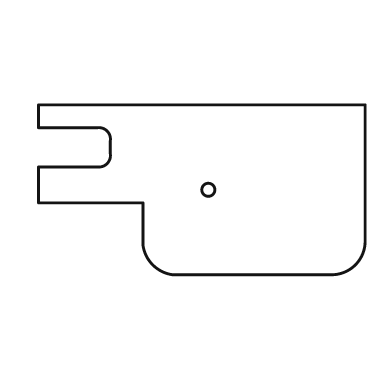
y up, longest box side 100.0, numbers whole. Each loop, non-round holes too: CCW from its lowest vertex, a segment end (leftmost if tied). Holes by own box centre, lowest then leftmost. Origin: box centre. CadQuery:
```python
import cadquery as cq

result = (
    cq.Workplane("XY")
    .moveTo(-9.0, -26.0)
    .lineTo(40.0, -26.0)
    .threePointArc((47.0, -23.0), (50.0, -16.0))
    .lineTo(50.0, 26.0)
    .lineTo(-50.0, 26.0)
    .lineTo(-50.0, 19.0)
    .lineTo(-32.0, 19.0)
    .threePointArc((-29.0, 18.0), (-28.0, 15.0))
    .lineTo(-28.0, 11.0)
    .threePointArc((-29.0, 8.0), (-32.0, 7.0))
    .lineTo(-50.0, 7.0)
    .lineTo(-50.0, -4.0)
    .lineTo(-18.0, -4.0)
    .lineTo(-18.0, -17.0)
    .threePointArc((-15.0, -23.0), (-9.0, -26.0))
    .close()
    .moveTo(2.0, 0.0)
    .circle(2.0)
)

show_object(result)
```